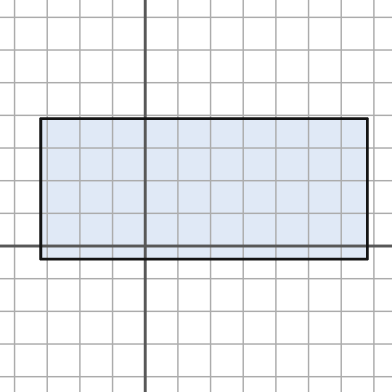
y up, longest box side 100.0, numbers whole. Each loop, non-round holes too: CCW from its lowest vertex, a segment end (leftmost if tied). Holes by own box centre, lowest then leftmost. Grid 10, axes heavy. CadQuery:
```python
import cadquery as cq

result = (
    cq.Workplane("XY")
    .moveTo(-32.0, -4.0)
    .lineTo(68.0, -4.0)
    .lineTo(68.0, 39.0)
    .lineTo(-32.0, 39.0)
    .close()
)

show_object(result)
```